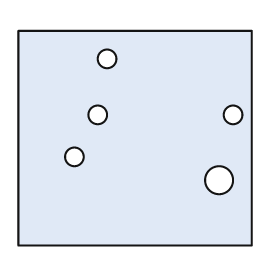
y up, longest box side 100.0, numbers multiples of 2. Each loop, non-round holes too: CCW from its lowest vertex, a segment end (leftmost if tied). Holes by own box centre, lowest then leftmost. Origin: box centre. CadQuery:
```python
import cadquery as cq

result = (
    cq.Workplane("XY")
    .moveTo(-50.0, -46.0)
    .lineTo(50.0, -46.0)
    .lineTo(50.0, 46.0)
    .lineTo(-50.0, 46.0)
    .close()
    .moveTo(36.0, -18.0)
    .circle(6.0)
    .moveTo(-26.0, -8.0)
    .circle(4.0)
    .moveTo(-16.0, 10.0)
    .circle(4.0)
    .moveTo(42.0, 10.0)
    .circle(4.0)
    .moveTo(-12.0, 34.0)
    .circle(4.0)
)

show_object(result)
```